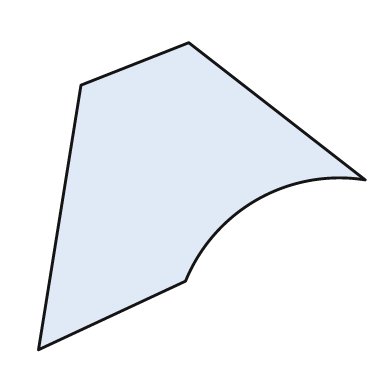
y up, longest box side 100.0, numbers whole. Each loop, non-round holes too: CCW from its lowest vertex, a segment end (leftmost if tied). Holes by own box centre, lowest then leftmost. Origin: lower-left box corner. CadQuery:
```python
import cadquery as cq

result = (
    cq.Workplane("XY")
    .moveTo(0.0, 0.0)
    .lineTo(45.0, 21.0)
    .threePointArc((67.0, 46.0), (100.0, 52.0))
    .lineTo(46.0, 94.0)
    .lineTo(13.0, 81.0)
    .close()
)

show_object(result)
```